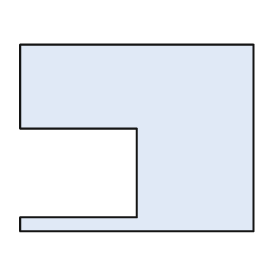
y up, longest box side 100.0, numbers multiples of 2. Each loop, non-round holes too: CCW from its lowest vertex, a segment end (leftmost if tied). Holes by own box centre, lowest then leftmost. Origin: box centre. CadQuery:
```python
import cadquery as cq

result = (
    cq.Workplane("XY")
    .moveTo(-50.0, -40.0)
    .lineTo(50.0, -40.0)
    .lineTo(50.0, 40.0)
    .lineTo(-50.0, 40.0)
    .lineTo(-50.0, 4.0)
    .lineTo(0.0, 4.0)
    .lineTo(0.0, -34.0)
    .lineTo(-50.0, -34.0)
    .close()
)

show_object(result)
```